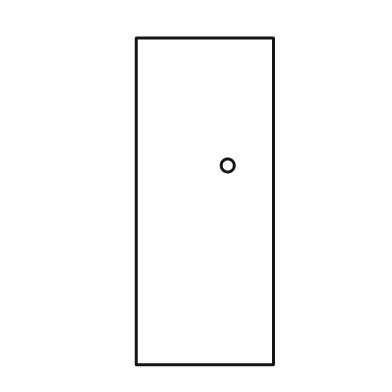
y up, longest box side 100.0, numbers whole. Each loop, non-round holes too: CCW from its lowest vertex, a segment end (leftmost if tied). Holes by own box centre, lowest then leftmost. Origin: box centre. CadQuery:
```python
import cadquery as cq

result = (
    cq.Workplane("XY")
    .moveTo(-21.0, -50.0)
    .lineTo(21.0, -50.0)
    .lineTo(21.0, 50.0)
    .lineTo(-21.0, 50.0)
    .close()
    .moveTo(7.0, 11.0)
    .circle(2.0)
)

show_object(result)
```